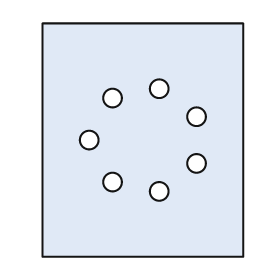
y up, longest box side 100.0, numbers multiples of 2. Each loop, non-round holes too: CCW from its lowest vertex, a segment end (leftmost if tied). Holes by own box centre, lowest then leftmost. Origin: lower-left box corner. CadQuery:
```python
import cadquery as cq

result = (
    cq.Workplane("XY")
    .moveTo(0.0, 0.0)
    .lineTo(86.0, 0.0)
    .lineTo(86.0, 100.0)
    .lineTo(0.0, 100.0)
    .close()
    .moveTo(50.0, 28.0)
    .circle(4.0)
    .moveTo(30.0, 32.0)
    .circle(4.0)
    .moveTo(66.0, 40.0)
    .circle(4.0)
    .moveTo(20.0, 50.0)
    .circle(4.0)
    .moveTo(66.0, 60.0)
    .circle(4.0)
    .moveTo(30.0, 68.0)
    .circle(4.0)
    .moveTo(50.0, 72.0)
    .circle(4.0)
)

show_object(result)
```